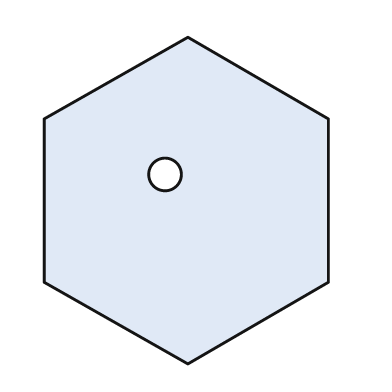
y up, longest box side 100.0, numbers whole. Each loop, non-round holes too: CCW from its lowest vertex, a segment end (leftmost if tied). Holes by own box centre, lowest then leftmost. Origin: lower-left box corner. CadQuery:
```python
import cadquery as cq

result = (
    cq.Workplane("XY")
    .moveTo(44.0, 0.0)
    .lineTo(87.0, 25.0)
    .lineTo(87.0, 75.0)
    .lineTo(44.0, 100.0)
    .lineTo(0.0, 75.0)
    .lineTo(0.0, 25.0)
    .close()
    .moveTo(37.0, 58.0)
    .circle(5.0)
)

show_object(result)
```